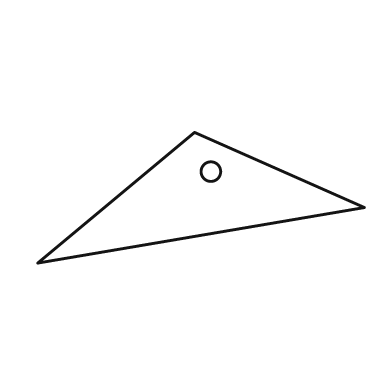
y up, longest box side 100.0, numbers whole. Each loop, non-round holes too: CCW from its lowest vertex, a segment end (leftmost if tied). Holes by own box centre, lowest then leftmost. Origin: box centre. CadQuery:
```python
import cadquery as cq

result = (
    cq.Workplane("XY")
    .moveTo(-50.0, -20.0)
    .lineTo(50.0, -3.0)
    .lineTo(-2.0, 20.0)
    .close()
    .moveTo(3.0, 8.0)
    .circle(3.0)
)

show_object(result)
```